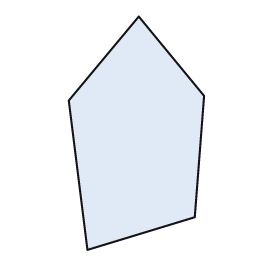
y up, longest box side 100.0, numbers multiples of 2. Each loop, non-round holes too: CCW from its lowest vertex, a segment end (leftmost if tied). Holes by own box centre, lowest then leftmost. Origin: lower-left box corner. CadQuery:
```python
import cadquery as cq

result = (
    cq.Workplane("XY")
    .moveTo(8.0, 0.0)
    .lineTo(54.0, 14.0)
    .lineTo(58.0, 66.0)
    .lineTo(30.0, 100.0)
    .lineTo(0.0, 64.0)
    .close()
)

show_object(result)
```